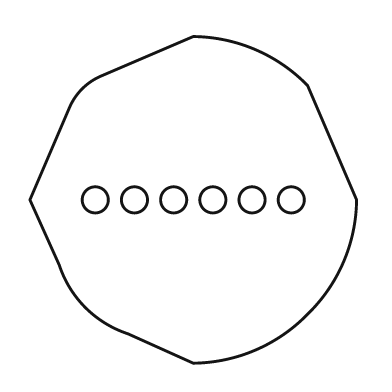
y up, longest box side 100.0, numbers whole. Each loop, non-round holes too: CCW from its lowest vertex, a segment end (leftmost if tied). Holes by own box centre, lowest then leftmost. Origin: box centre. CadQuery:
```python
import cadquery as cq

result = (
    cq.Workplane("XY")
    .moveTo(0.0, -50.0)
    .threePointArc((19.0, -46.0), (35.0, -35.0))
    .threePointArc((46.0, -19.0), (50.0, 0.0))
    .lineTo(35.0, 35.0)
    .threePointArc((19.0, 46.0), (0.0, 50.0))
    .lineTo(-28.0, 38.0)
    .threePointArc((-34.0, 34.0), (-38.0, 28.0))
    .lineTo(-50.0, 0.0)
    .lineTo(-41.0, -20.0)
    .threePointArc((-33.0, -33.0), (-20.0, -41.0))
    .close()
    .moveTo(-30.0, 0.0)
    .circle(4.0)
    .moveTo(-18.0, 0.0)
    .circle(4.0)
    .moveTo(-6.0, 0.0)
    .circle(4.0)
    .moveTo(6.0, 0.0)
    .circle(4.0)
    .moveTo(18.0, 0.0)
    .circle(4.0)
    .moveTo(30.0, 0.0)
    .circle(4.0)
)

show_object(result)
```